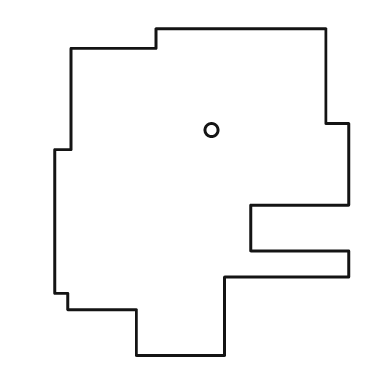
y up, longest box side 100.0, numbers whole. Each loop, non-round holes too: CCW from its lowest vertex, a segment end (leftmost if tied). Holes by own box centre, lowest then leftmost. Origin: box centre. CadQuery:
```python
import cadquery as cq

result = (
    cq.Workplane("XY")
    .moveTo(-20.0, -50.0)
    .lineTo(7.0, -50.0)
    .lineTo(7.0, -26.0)
    .lineTo(45.0, -26.0)
    .lineTo(45.0, -18.0)
    .lineTo(15.0, -18.0)
    .lineTo(15.0, -4.0)
    .lineTo(45.0, -4.0)
    .lineTo(45.0, 21.0)
    .lineTo(38.0, 21.0)
    .lineTo(38.0, 50.0)
    .lineTo(-14.0, 50.0)
    .lineTo(-14.0, 44.0)
    .lineTo(-40.0, 44.0)
    .lineTo(-40.0, 13.0)
    .lineTo(-45.0, 13.0)
    .lineTo(-45.0, -31.0)
    .lineTo(-41.0, -31.0)
    .lineTo(-41.0, -36.0)
    .lineTo(-20.0, -36.0)
    .close()
    .moveTo(3.0, 19.0)
    .circle(2.0)
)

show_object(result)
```